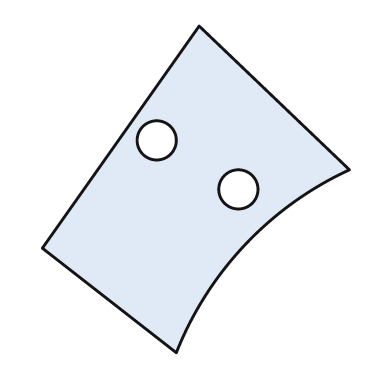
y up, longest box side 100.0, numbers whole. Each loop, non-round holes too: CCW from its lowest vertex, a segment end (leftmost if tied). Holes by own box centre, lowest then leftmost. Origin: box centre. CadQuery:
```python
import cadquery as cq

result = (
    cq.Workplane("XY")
    .moveTo(-6.0, -50.0)
    .threePointArc((15.0, -17.0), (47.0, 6.0))
    .lineTo(1.0, 50.0)
    .lineTo(-47.0, -18.0)
    .close()
    .moveTo(13.0, 0.0)
    .circle(6.0)
    .moveTo(-12.0, 15.0)
    .circle(6.0)
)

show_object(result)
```